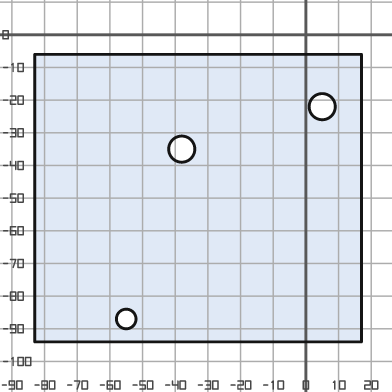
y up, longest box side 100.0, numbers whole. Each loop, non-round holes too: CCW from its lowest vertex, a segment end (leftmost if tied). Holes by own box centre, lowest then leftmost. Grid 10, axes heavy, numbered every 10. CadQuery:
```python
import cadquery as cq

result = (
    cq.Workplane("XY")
    .moveTo(-83.0, -94.0)
    .lineTo(17.0, -94.0)
    .lineTo(17.0, -6.0)
    .lineTo(-83.0, -6.0)
    .close()
    .moveTo(-55.0, -87.0)
    .circle(3.0)
    .moveTo(-38.0, -35.0)
    .circle(4.0)
    .moveTo(5.0, -22.0)
    .circle(4.0)
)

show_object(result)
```